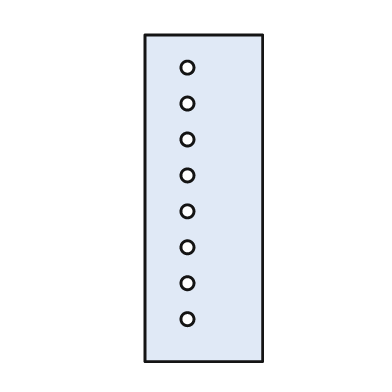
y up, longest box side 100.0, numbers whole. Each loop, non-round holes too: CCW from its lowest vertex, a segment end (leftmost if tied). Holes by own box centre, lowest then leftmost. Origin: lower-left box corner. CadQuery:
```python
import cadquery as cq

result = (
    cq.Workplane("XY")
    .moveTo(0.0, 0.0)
    .lineTo(36.0, 0.0)
    .lineTo(36.0, 100.0)
    .lineTo(0.0, 100.0)
    .close()
    .moveTo(13.0, 13.0)
    .circle(2.0)
    .moveTo(13.0, 24.0)
    .circle(2.0)
    .moveTo(13.0, 35.0)
    .circle(2.0)
    .moveTo(13.0, 46.0)
    .circle(2.0)
    .moveTo(13.0, 57.0)
    .circle(2.0)
    .moveTo(13.0, 68.0)
    .circle(2.0)
    .moveTo(13.0, 79.0)
    .circle(2.0)
    .moveTo(13.0, 90.0)
    .circle(2.0)
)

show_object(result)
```